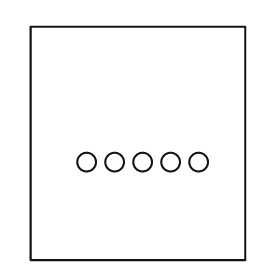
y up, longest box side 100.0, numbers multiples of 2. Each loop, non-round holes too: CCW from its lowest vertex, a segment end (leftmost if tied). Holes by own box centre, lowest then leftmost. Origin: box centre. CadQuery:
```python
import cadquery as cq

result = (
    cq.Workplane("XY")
    .moveTo(-46.0, -50.0)
    .lineTo(46.0, -50.0)
    .lineTo(46.0, 50.0)
    .lineTo(-46.0, 50.0)
    .close()
    .moveTo(-22.0, -8.0)
    .circle(4.0)
    .moveTo(-10.0, -8.0)
    .circle(4.0)
    .moveTo(2.0, -8.0)
    .circle(4.0)
    .moveTo(14.0, -8.0)
    .circle(4.0)
    .moveTo(26.0, -8.0)
    .circle(4.0)
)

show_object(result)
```